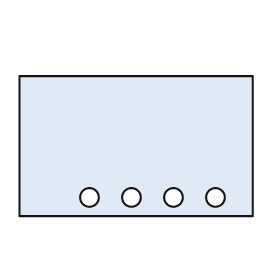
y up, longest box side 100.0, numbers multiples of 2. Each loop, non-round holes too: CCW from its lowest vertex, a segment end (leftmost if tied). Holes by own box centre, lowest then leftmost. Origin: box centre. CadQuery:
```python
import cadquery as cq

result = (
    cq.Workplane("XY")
    .moveTo(-50.0, -30.0)
    .lineTo(50.0, -30.0)
    .lineTo(50.0, 30.0)
    .lineTo(-50.0, 30.0)
    .close()
    .moveTo(-20.0, -22.0)
    .circle(4.0)
    .moveTo(-2.0, -22.0)
    .circle(4.0)
    .moveTo(16.0, -22.0)
    .circle(4.0)
    .moveTo(34.0, -22.0)
    .circle(4.0)
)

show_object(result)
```